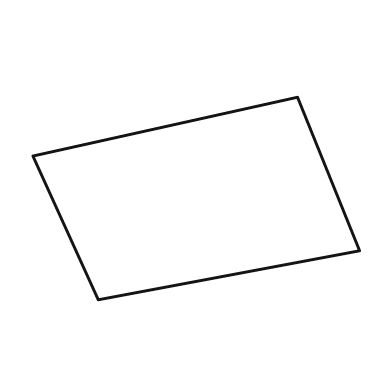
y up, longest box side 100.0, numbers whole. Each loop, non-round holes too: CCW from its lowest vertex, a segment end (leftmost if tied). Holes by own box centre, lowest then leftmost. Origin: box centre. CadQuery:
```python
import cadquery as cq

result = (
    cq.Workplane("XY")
    .moveTo(-30.0, -31.0)
    .lineTo(50.0, -16.0)
    .lineTo(31.0, 31.0)
    .lineTo(-50.0, 13.0)
    .close()
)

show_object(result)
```